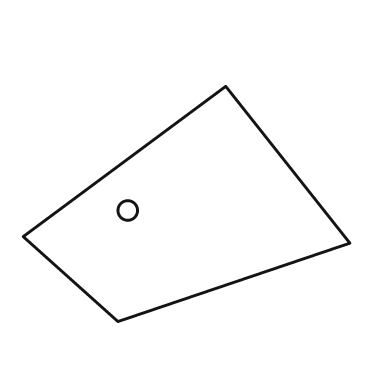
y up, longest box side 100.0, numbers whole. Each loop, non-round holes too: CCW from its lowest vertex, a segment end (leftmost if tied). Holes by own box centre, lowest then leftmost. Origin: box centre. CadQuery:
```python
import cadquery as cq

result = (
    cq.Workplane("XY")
    .moveTo(-21.0, -36.0)
    .lineTo(50.0, -12.0)
    .lineTo(12.0, 36.0)
    .lineTo(-50.0, -10.0)
    .close()
    .moveTo(-18.0, -2.0)
    .circle(3.0)
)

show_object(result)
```